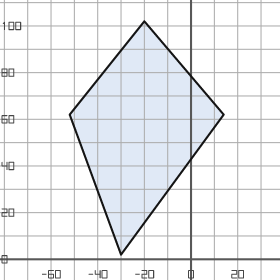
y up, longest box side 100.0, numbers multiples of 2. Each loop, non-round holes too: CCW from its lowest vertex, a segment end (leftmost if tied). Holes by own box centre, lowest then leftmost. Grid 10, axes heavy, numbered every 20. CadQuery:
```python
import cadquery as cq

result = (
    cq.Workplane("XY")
    .moveTo(-30.0, 2.0)
    .lineTo(14.0, 62.0)
    .lineTo(-20.0, 102.0)
    .lineTo(-52.0, 62.0)
    .close()
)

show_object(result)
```